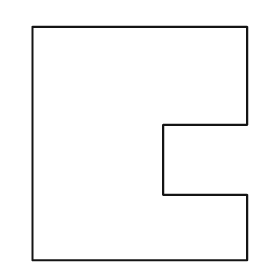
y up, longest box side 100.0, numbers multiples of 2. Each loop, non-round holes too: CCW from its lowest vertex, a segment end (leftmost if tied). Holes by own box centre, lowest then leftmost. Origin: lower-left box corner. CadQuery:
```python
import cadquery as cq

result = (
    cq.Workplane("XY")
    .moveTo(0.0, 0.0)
    .lineTo(92.0, 0.0)
    .lineTo(92.0, 28.0)
    .lineTo(56.0, 28.0)
    .lineTo(56.0, 58.0)
    .lineTo(92.0, 58.0)
    .lineTo(92.0, 100.0)
    .lineTo(0.0, 100.0)
    .close()
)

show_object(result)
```